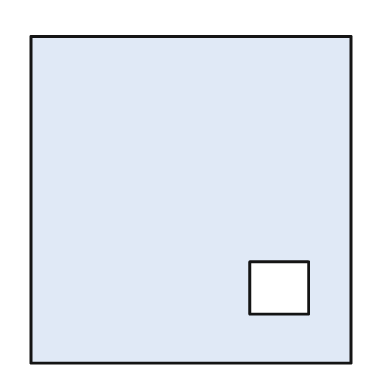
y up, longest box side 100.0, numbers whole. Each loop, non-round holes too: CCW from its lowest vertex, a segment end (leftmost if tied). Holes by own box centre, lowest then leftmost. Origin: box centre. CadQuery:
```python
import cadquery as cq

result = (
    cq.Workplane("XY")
    .moveTo(-49.0, -50.0)
    .lineTo(49.0, -50.0)
    .lineTo(49.0, 50.0)
    .lineTo(-49.0, 50.0)
    .close()
    .moveTo(18.0, -35.0)
    .lineTo(36.0, -35.0)
    .lineTo(36.0, -19.0)
    .lineTo(18.0, -19.0)
    .close()
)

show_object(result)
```